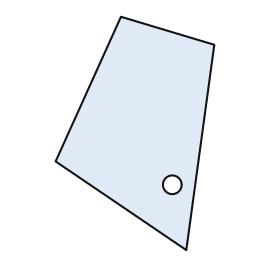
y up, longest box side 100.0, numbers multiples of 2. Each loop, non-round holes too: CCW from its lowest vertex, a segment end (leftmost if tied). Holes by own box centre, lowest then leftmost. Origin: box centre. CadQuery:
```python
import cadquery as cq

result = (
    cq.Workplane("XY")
    .moveTo(22.0, -50.0)
    .lineTo(34.0, 38.0)
    .lineTo(-6.0, 50.0)
    .lineTo(-34.0, -12.0)
    .close()
    .moveTo(16.0, -22.0)
    .circle(4.0)
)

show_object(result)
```